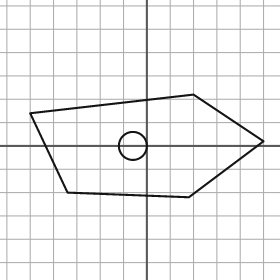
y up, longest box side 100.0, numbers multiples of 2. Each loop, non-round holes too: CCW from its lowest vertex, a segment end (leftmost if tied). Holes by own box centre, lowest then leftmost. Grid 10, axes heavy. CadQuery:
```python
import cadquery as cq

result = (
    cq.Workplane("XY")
    .moveTo(18.0, -22.0)
    .lineTo(50.0, 2.0)
    .lineTo(20.0, 22.0)
    .lineTo(-50.0, 14.0)
    .lineTo(-34.0, -20.0)
    .close()
    .moveTo(-6.0, 0.0)
    .circle(6.0)
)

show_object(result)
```